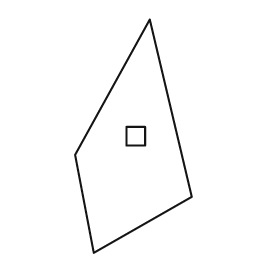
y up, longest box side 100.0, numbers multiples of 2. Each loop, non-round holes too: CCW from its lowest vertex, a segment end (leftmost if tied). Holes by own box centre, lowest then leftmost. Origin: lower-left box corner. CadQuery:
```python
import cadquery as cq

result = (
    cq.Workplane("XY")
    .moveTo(8.0, 0.0)
    .lineTo(50.0, 24.0)
    .lineTo(32.0, 100.0)
    .lineTo(0.0, 42.0)
    .close()
    .moveTo(22.0, 46.0)
    .lineTo(30.0, 46.0)
    .lineTo(30.0, 54.0)
    .lineTo(22.0, 54.0)
    .close()
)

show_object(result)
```